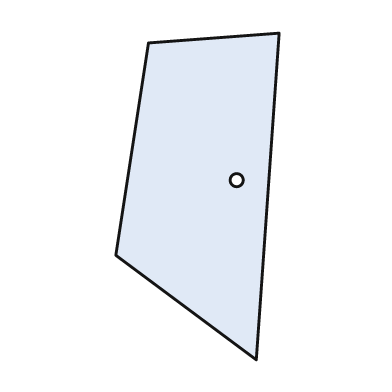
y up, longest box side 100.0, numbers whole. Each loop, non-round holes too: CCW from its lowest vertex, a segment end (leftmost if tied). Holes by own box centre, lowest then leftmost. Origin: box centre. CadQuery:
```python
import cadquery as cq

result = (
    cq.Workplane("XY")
    .moveTo(18.0, -50.0)
    .lineTo(25.0, 50.0)
    .lineTo(-15.0, 47.0)
    .lineTo(-25.0, -18.0)
    .close()
    .moveTo(12.0, 5.0)
    .circle(2.0)
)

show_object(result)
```